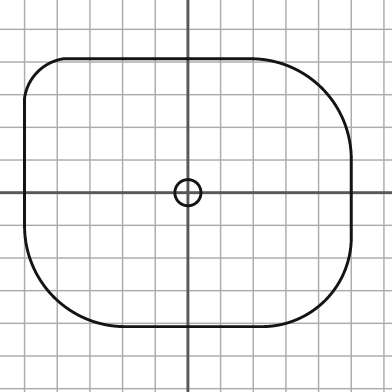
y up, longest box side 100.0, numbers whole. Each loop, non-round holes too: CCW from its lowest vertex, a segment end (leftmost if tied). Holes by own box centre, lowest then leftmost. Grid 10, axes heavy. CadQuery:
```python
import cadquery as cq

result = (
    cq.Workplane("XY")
    .moveTo(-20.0, -41.0)
    .lineTo(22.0, -41.0)
    .threePointArc((42.0, -33.0), (50.0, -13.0))
    .lineTo(50.0, 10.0)
    .threePointArc((41.0, 32.0), (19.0, 41.0))
    .lineTo(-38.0, 41.0)
    .threePointArc((-46.0, 37.0), (-50.0, 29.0))
    .lineTo(-50.0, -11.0)
    .threePointArc((-41.0, -32.0), (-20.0, -41.0))
    .close()
    .moveTo(0.0, 0.0)
    .circle(4.0)
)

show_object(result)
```